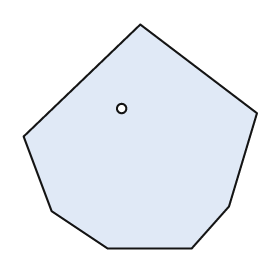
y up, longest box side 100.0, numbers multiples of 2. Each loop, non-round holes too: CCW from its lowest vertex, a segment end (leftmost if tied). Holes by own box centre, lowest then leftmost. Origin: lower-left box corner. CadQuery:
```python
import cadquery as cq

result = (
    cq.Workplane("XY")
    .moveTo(36.0, 0.0)
    .lineTo(72.0, 0.0)
    .lineTo(88.0, 18.0)
    .lineTo(100.0, 58.0)
    .lineTo(50.0, 96.0)
    .lineTo(0.0, 48.0)
    .lineTo(12.0, 16.0)
    .close()
    .moveTo(42.0, 60.0)
    .circle(2.0)
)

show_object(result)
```